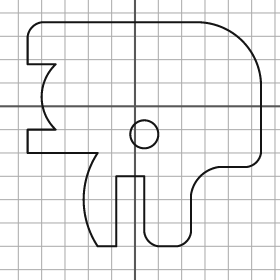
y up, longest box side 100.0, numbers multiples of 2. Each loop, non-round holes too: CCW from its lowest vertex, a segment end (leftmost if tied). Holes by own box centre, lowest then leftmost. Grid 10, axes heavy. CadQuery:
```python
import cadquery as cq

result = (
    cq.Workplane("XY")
    .moveTo(-16.0, -60.0)
    .lineTo(-8.0, -60.0)
    .lineTo(-8.0, -30.0)
    .lineTo(4.0, -30.0)
    .lineTo(4.0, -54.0)
    .threePointArc((6.0, -58.0), (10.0, -60.0))
    .lineTo(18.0, -60.0)
    .threePointArc((22.0, -58.0), (24.0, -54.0))
    .lineTo(24.0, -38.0)
    .threePointArc((28.0, -30.0), (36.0, -26.0))
    .lineTo(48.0, -26.0)
    .threePointArc((52.0, -24.0), (54.0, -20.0))
    .lineTo(54.0, 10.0)
    .threePointArc((46.0, 28.0), (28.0, 36.0))
    .lineTo(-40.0, 36.0)
    .threePointArc((-44.0, 34.0), (-46.0, 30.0))
    .lineTo(-46.0, 18.0)
    .lineTo(-34.0, 18.0)
    .threePointArc((-40.0, 4.0), (-34.0, -10.0))
    .lineTo(-46.0, -10.0)
    .lineTo(-46.0, -20.0)
    .lineTo(-16.0, -20.0)
    .threePointArc((-22.0, -40.0), (-16.0, -60.0))
    .close()
    .moveTo(4.0, -12.0)
    .circle(6.0)
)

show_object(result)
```